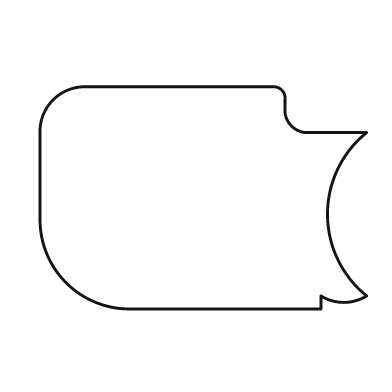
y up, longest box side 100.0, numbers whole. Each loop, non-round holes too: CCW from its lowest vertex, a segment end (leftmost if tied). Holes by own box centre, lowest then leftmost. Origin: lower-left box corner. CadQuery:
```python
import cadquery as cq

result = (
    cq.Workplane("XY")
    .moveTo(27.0, 0.0)
    .lineTo(86.0, 0.0)
    .lineTo(86.0, 4.0)
    .threePointArc((93.0, 2.0), (100.0, 4.0))
    .threePointArc((88.0, 29.0), (100.0, 54.0))
    .lineTo(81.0, 54.0)
    .threePointArc((77.0, 56.0), (75.0, 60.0))
    .lineTo(75.0, 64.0)
    .threePointArc((74.0, 67.0), (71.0, 68.0))
    .lineTo(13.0, 68.0)
    .threePointArc((4.0, 64.0), (0.0, 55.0))
    .lineTo(0.0, 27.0)
    .threePointArc((8.0, 8.0), (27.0, 0.0))
    .close()
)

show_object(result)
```